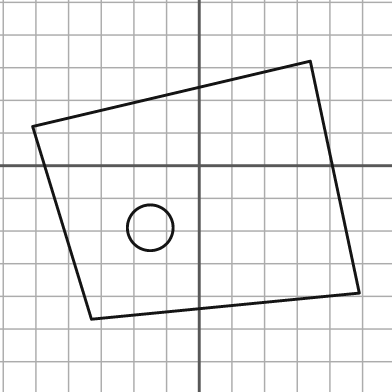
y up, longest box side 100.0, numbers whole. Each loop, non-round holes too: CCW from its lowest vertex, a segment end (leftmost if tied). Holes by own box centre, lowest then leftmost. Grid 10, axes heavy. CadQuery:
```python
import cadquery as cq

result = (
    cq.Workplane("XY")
    .moveTo(-33.0, -47.0)
    .lineTo(49.0, -39.0)
    .lineTo(34.0, 32.0)
    .lineTo(-51.0, 12.0)
    .close()
    .moveTo(-15.0, -19.0)
    .circle(7.0)
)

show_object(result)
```